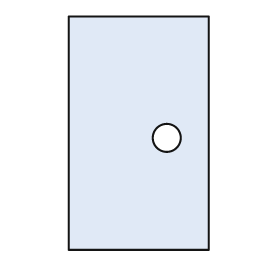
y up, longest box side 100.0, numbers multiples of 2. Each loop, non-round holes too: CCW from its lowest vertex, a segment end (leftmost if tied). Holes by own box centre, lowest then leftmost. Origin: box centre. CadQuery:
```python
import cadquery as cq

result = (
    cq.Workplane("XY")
    .moveTo(-30.0, -50.0)
    .lineTo(30.0, -50.0)
    .lineTo(30.0, 50.0)
    .lineTo(-30.0, 50.0)
    .close()
    .moveTo(12.0, -2.0)
    .circle(6.0)
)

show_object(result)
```